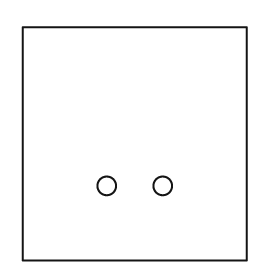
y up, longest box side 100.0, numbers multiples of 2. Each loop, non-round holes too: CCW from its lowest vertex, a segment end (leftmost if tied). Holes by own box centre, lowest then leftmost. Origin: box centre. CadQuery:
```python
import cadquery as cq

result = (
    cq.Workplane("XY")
    .moveTo(-48.0, -50.0)
    .lineTo(48.0, -50.0)
    .lineTo(48.0, 50.0)
    .lineTo(-48.0, 50.0)
    .close()
    .moveTo(-12.0, -18.0)
    .circle(4.0)
    .moveTo(12.0, -18.0)
    .circle(4.0)
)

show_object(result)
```